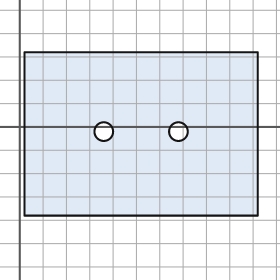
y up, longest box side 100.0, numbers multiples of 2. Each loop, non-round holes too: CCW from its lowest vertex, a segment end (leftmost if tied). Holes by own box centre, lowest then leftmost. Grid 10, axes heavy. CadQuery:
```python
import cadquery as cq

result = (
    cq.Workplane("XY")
    .moveTo(2.0, -38.0)
    .lineTo(102.0, -38.0)
    .lineTo(102.0, 32.0)
    .lineTo(2.0, 32.0)
    .close()
    .moveTo(36.0, -2.0)
    .circle(4.0)
    .moveTo(68.0, -2.0)
    .circle(4.0)
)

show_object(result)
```